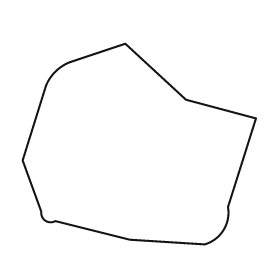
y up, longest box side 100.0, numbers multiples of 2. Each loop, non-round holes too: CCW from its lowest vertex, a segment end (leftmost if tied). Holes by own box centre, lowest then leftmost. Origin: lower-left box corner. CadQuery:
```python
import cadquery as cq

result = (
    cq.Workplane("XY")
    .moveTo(78.0, 0.0)
    .threePointArc((86.0, 6.0), (88.0, 16.0))
    .lineTo(100.0, 54.0)
    .lineTo(70.0, 62.0)
    .lineTo(44.0, 86.0)
    .lineTo(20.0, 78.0)
    .threePointArc((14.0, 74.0), (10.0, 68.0))
    .lineTo(0.0, 36.0)
    .lineTo(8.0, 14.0)
    .threePointArc((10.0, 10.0), (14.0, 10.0))
    .lineTo(46.0, 2.0)
    .close()
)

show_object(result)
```